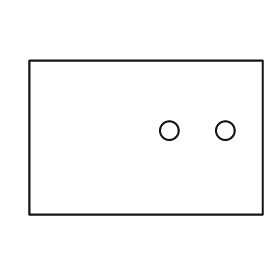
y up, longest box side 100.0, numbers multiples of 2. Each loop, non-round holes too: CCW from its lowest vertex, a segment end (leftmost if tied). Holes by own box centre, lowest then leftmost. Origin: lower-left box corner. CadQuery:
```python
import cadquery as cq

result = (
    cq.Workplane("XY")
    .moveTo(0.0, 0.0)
    .lineTo(100.0, 0.0)
    .lineTo(100.0, 66.0)
    .lineTo(0.0, 66.0)
    .close()
    .moveTo(60.0, 36.0)
    .circle(4.0)
    .moveTo(84.0, 36.0)
    .circle(4.0)
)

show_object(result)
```